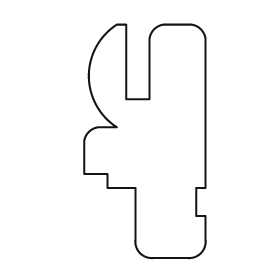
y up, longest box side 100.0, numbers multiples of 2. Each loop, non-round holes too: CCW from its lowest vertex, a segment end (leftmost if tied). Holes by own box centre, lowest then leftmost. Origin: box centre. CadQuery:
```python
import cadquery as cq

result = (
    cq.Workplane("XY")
    .moveTo(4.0, -50.0)
    .lineTo(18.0, -50.0)
    .threePointArc((24.0, -48.0), (26.0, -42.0))
    .lineTo(26.0, -32.0)
    .lineTo(22.0, -32.0)
    .lineTo(22.0, -20.0)
    .lineTo(26.0, -20.0)
    .lineTo(26.0, 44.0)
    .threePointArc((24.0, 48.0), (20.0, 50.0))
    .lineTo(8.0, 50.0)
    .threePointArc((4.0, 48.0), (2.0, 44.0))
    .lineTo(2.0, 18.0)
    .lineTo(-8.0, 18.0)
    .lineTo(-8.0, 50.0)
    .lineTo(-12.0, 50.0)
    .threePointArc((-24.0, 28.0), (-12.0, 6.0))
    .lineTo(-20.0, 6.0)
    .threePointArc((-24.0, 4.0), (-26.0, 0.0))
    .lineTo(-26.0, -14.0)
    .lineTo(-16.0, -14.0)
    .lineTo(-16.0, -20.0)
    .lineTo(-4.0, -20.0)
    .lineTo(-4.0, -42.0)
    .threePointArc((-2.0, -48.0), (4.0, -50.0))
    .close()
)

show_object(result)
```